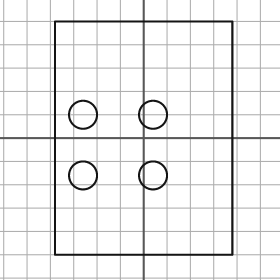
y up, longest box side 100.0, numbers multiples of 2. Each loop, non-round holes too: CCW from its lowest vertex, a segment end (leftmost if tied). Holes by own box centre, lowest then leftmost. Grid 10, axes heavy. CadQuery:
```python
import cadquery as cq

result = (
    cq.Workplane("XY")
    .moveTo(-38.0, -50.0)
    .lineTo(38.0, -50.0)
    .lineTo(38.0, 50.0)
    .lineTo(-38.0, 50.0)
    .close()
    .moveTo(-26.0, -16.0)
    .circle(6.0)
    .moveTo(4.0, -16.0)
    .circle(6.0)
    .moveTo(-26.0, 10.0)
    .circle(6.0)
    .moveTo(4.0, 10.0)
    .circle(6.0)
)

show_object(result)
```